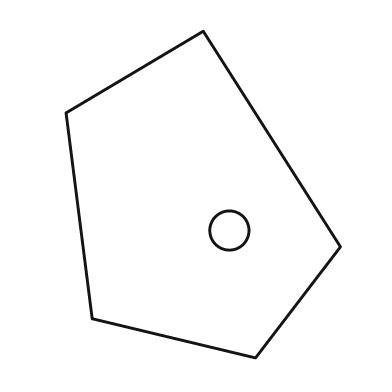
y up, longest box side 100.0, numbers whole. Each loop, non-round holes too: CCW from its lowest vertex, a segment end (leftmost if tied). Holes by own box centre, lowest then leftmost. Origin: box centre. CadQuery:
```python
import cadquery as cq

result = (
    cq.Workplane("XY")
    .moveTo(16.0, -50.0)
    .lineTo(42.0, -16.0)
    .lineTo(0.0, 50.0)
    .lineTo(-42.0, 25.0)
    .lineTo(-34.0, -38.0)
    .close()
    .moveTo(8.0, -11.0)
    .circle(6.0)
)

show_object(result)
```